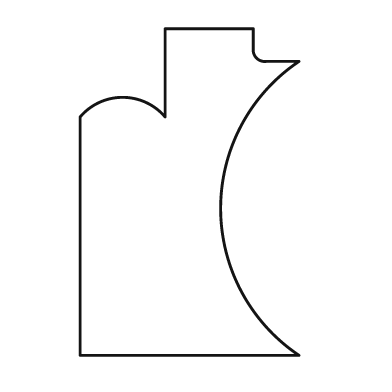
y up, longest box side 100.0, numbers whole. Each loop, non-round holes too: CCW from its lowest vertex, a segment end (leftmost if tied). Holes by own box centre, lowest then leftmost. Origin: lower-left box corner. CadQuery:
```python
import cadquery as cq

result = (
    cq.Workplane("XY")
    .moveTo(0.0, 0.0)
    .lineTo(67.0, 0.0)
    .threePointArc((43.0, 45.0), (67.0, 90.0))
    .lineTo(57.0, 90.0)
    .threePointArc((54.0, 91.0), (53.0, 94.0))
    .lineTo(53.0, 100.0)
    .lineTo(26.0, 100.0)
    .lineTo(26.0, 73.0)
    .threePointArc((13.0, 79.0), (0.0, 73.0))
    .close()
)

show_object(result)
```